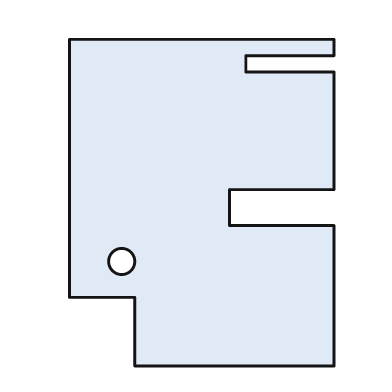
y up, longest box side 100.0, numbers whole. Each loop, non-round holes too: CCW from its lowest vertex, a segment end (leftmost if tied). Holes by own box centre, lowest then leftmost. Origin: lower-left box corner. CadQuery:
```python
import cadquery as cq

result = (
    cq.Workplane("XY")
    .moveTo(20.0, 0.0)
    .lineTo(81.0, 0.0)
    .lineTo(81.0, 43.0)
    .lineTo(49.0, 43.0)
    .lineTo(49.0, 54.0)
    .lineTo(81.0, 54.0)
    .lineTo(81.0, 90.0)
    .lineTo(54.0, 90.0)
    .lineTo(54.0, 95.0)
    .lineTo(81.0, 95.0)
    .lineTo(81.0, 100.0)
    .lineTo(0.0, 100.0)
    .lineTo(0.0, 21.0)
    .lineTo(20.0, 21.0)
    .close()
    .moveTo(16.0, 32.0)
    .circle(4.0)
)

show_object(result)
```